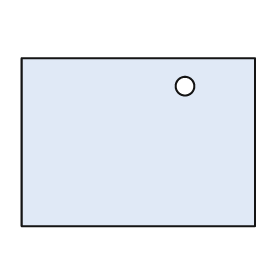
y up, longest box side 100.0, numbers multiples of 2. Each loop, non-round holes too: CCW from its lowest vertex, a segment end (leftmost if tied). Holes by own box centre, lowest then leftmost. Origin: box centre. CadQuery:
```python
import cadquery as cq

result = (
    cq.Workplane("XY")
    .moveTo(-50.0, -36.0)
    .lineTo(50.0, -36.0)
    .lineTo(50.0, 36.0)
    .lineTo(-50.0, 36.0)
    .close()
    .moveTo(20.0, 24.0)
    .circle(4.0)
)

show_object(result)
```